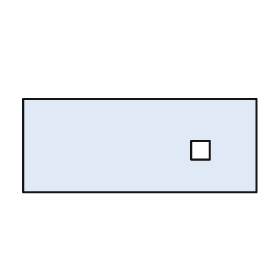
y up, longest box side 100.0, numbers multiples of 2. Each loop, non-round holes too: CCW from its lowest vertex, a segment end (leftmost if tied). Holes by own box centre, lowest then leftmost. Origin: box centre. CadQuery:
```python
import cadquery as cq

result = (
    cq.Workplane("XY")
    .moveTo(-50.0, -20.0)
    .lineTo(50.0, -20.0)
    .lineTo(50.0, 20.0)
    .lineTo(-50.0, 20.0)
    .close()
    .moveTo(22.0, -6.0)
    .lineTo(30.0, -6.0)
    .lineTo(30.0, 2.0)
    .lineTo(22.0, 2.0)
    .close()
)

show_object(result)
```